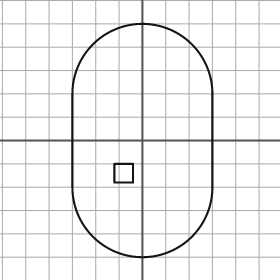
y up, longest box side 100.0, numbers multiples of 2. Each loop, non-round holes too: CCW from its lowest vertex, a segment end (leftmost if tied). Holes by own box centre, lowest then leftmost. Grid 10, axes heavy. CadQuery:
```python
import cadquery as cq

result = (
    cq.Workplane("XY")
    .moveTo(-30.0, -20.0)
    .threePointArc((0.0, -50.0), (30.0, -20.0))
    .lineTo(30.0, 20.0)
    .threePointArc((0.0, 50.0), (-30.0, 20.0))
    .close()
    .moveTo(-12.0, -18.0)
    .lineTo(-4.0, -18.0)
    .lineTo(-4.0, -10.0)
    .lineTo(-12.0, -10.0)
    .close()
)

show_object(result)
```